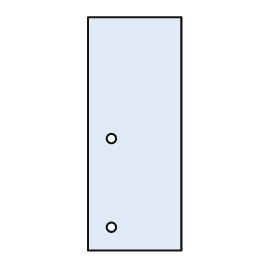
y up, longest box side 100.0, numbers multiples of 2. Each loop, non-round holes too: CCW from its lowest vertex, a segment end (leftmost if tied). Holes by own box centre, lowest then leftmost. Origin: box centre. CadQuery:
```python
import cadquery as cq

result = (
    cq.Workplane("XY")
    .moveTo(-20.0, -50.0)
    .lineTo(20.0, -50.0)
    .lineTo(20.0, 50.0)
    .lineTo(-20.0, 50.0)
    .close()
    .moveTo(-10.0, -40.0)
    .circle(2.0)
    .moveTo(-10.0, -2.0)
    .circle(2.0)
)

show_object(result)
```